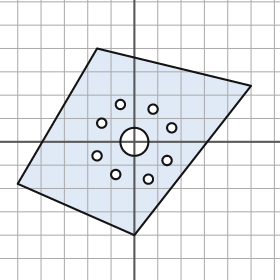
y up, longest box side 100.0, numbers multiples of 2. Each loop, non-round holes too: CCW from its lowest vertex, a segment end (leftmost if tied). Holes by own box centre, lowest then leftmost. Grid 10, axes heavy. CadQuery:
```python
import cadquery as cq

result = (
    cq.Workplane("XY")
    .moveTo(0.0, -40.0)
    .lineTo(50.0, 24.0)
    .lineTo(-16.0, 40.0)
    .lineTo(-50.0, -18.0)
    .close()
    .moveTo(6.0, -16.0)
    .circle(2.0)
    .moveTo(-8.0, -14.0)
    .circle(2.0)
    .moveTo(14.0, -8.0)
    .circle(2.0)
    .moveTo(-16.0, -6.0)
    .circle(2.0)
    .moveTo(0.0, 0.0)
    .circle(6.0)
    .moveTo(16.0, 6.0)
    .circle(2.0)
    .moveTo(-14.0, 8.0)
    .circle(2.0)
    .moveTo(8.0, 14.0)
    .circle(2.0)
    .moveTo(-6.0, 16.0)
    .circle(2.0)
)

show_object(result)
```